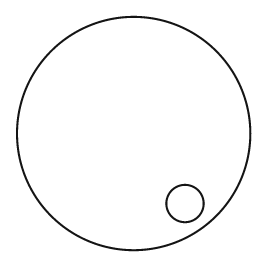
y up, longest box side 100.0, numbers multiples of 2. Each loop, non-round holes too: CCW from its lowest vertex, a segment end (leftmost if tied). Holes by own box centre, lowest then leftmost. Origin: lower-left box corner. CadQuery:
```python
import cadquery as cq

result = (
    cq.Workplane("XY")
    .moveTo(50.0, 50.0)
    .circle(50.0)
    .moveTo(72.0, 20.0)
    .circle(8.0)
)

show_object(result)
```